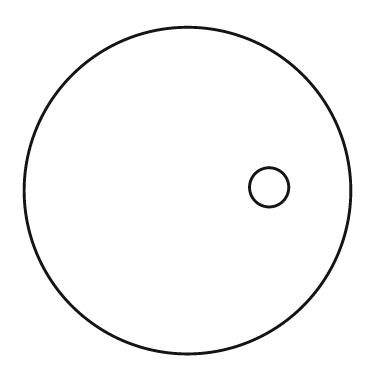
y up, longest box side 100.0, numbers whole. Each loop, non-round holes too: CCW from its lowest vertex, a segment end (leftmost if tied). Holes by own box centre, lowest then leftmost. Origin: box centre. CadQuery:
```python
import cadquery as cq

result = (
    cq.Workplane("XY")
    .moveTo(0.0, 0.0)
    .circle(50.0)
    .moveTo(25.0, 1.0)
    .circle(6.0)
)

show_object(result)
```